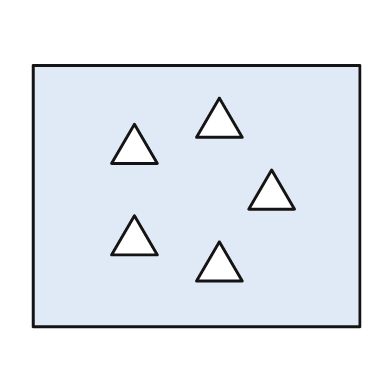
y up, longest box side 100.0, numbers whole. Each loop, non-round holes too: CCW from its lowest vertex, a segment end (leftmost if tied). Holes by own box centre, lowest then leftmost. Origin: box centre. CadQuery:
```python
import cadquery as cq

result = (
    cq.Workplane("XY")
    .moveTo(-50.0, -40.0)
    .lineTo(50.0, -40.0)
    .lineTo(50.0, 40.0)
    .lineTo(-50.0, 40.0)
    .close()
    .moveTo(0.0, -26.0)
    .lineTo(14.0, -26.0)
    .lineTo(7.0, -14.0)
    .close()
    .moveTo(-26.0, -18.0)
    .lineTo(-12.0, -18.0)
    .lineTo(-19.0, -6.0)
    .close()
    .moveTo(16.0, -4.0)
    .lineTo(30.0, -4.0)
    .lineTo(23.0, 8.0)
    .close()
    .moveTo(-26.0, 10.0)
    .lineTo(-12.0, 10.0)
    .lineTo(-19.0, 22.0)
    .close()
    .moveTo(0.0, 18.0)
    .lineTo(14.0, 18.0)
    .lineTo(7.0, 30.0)
    .close()
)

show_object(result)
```